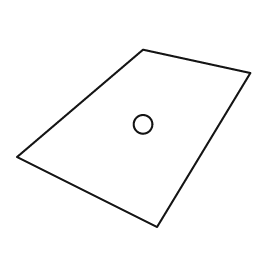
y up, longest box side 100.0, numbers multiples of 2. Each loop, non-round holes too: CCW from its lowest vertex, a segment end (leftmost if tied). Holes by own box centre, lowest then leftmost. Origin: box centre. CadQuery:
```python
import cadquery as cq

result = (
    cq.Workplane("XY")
    .moveTo(10.0, -38.0)
    .lineTo(50.0, 28.0)
    .lineTo(4.0, 38.0)
    .lineTo(-50.0, -8.0)
    .close()
    .moveTo(4.0, 6.0)
    .circle(4.0)
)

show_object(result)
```